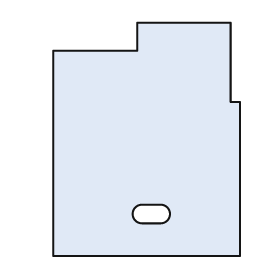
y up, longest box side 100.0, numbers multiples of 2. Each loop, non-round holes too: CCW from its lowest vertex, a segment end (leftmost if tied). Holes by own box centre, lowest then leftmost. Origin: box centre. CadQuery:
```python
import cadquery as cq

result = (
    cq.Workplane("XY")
    .moveTo(-40.0, -50.0)
    .lineTo(40.0, -50.0)
    .lineTo(40.0, 16.0)
    .lineTo(36.0, 16.0)
    .lineTo(36.0, 50.0)
    .lineTo(-4.0, 50.0)
    .lineTo(-4.0, 38.0)
    .lineTo(-40.0, 38.0)
    .close()
    .moveTo(-2.0, -36.0)
    .lineTo(6.0, -36.0)
    .threePointArc((10.0, -32.0), (6.0, -28.0))
    .lineTo(-2.0, -28.0)
    .threePointArc((-6.0, -32.0), (-2.0, -36.0))
    .close()
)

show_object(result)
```